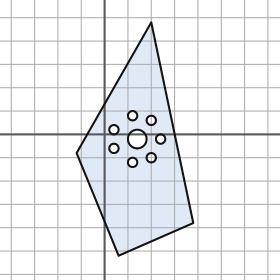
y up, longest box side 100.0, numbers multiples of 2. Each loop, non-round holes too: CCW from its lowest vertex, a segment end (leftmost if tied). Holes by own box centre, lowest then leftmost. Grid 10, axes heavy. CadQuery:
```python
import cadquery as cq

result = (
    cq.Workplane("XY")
    .moveTo(6.0, -52.0)
    .lineTo(38.0, -38.0)
    .lineTo(20.0, 48.0)
    .lineTo(-12.0, -8.0)
    .close()
    .moveTo(12.0, -12.0)
    .circle(2.0)
    .moveTo(20.0, -10.0)
    .circle(2.0)
    .moveTo(4.0, -6.0)
    .circle(2.0)
    .moveTo(14.0, -2.0)
    .circle(4.0)
    .moveTo(24.0, -2.0)
    .circle(2.0)
    .moveTo(4.0, 2.0)
    .circle(2.0)
    .moveTo(20.0, 6.0)
    .circle(2.0)
    .moveTo(12.0, 8.0)
    .circle(2.0)
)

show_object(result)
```